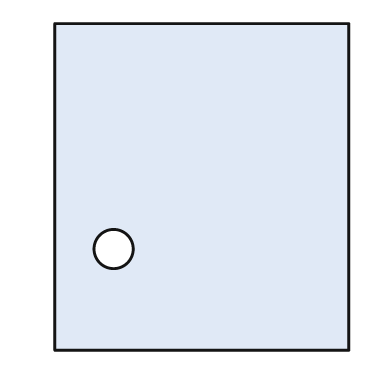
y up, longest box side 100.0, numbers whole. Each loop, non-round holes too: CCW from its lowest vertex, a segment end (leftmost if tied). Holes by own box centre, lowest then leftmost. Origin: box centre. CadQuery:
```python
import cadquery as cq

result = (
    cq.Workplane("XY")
    .moveTo(-45.0, -50.0)
    .lineTo(45.0, -50.0)
    .lineTo(45.0, 50.0)
    .lineTo(-45.0, 50.0)
    .close()
    .moveTo(-27.0, -19.0)
    .circle(6.0)
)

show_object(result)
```